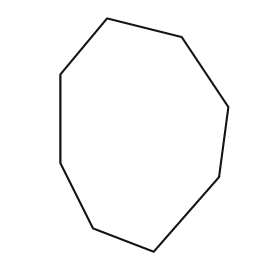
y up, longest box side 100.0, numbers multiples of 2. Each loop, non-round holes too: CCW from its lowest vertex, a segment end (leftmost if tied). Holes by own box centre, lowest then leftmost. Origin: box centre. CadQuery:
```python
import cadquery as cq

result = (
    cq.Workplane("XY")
    .moveTo(4.0, -50.0)
    .lineTo(32.0, -18.0)
    .lineTo(36.0, 12.0)
    .lineTo(16.0, 42.0)
    .lineTo(-16.0, 50.0)
    .lineTo(-36.0, 26.0)
    .lineTo(-36.0, -12.0)
    .lineTo(-22.0, -40.0)
    .close()
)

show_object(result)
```